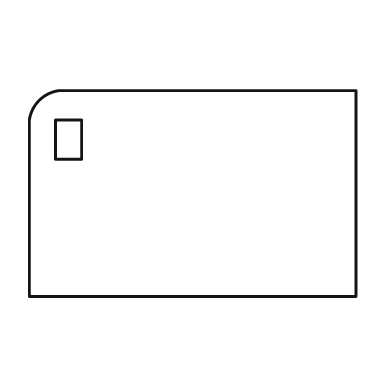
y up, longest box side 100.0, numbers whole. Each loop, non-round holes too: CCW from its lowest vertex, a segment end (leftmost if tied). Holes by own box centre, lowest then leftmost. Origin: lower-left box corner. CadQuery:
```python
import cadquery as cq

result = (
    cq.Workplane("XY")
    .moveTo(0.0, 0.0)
    .lineTo(100.0, 0.0)
    .lineTo(100.0, 63.0)
    .lineTo(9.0, 63.0)
    .threePointArc((3.0, 60.0), (0.0, 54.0))
    .close()
    .moveTo(8.0, 42.0)
    .lineTo(16.0, 42.0)
    .lineTo(16.0, 54.0)
    .lineTo(8.0, 54.0)
    .close()
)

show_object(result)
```